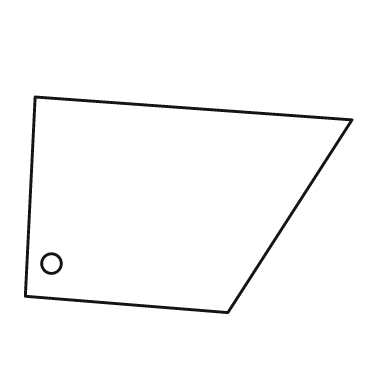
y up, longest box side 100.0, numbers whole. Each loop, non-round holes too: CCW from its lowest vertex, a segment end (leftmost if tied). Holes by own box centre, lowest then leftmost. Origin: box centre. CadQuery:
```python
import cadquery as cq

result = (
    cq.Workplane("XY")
    .moveTo(12.0, -33.0)
    .lineTo(50.0, 26.0)
    .lineTo(-47.0, 33.0)
    .lineTo(-50.0, -28.0)
    .close()
    .moveTo(-42.0, -18.0)
    .circle(3.0)
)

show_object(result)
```